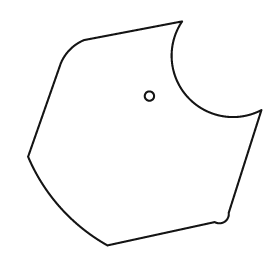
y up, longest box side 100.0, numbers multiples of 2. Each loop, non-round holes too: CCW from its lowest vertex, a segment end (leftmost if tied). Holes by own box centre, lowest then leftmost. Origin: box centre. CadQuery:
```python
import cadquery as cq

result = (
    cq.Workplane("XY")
    .moveTo(-16.0, -48.0)
    .lineTo(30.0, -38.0)
    .threePointArc((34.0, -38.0), (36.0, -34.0))
    .lineTo(50.0, 10.0)
    .threePointArc((18.0, 16.0), (16.0, 48.0))
    .lineTo(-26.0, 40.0)
    .threePointArc((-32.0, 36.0), (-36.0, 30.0))
    .lineTo(-50.0, -10.0)
    .threePointArc((-36.0, -32.0), (-16.0, -48.0))
    .close()
    .moveTo(2.0, 16.0)
    .circle(2.0)
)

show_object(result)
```